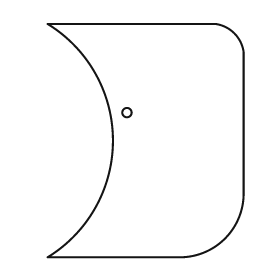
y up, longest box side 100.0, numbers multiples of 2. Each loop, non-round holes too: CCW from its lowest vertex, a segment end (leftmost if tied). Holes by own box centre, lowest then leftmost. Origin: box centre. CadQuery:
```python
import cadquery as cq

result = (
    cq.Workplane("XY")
    .moveTo(-42.0, -50.0)
    .lineTo(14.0, -50.0)
    .threePointArc((34.0, -42.0), (42.0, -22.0))
    .lineTo(42.0, 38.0)
    .threePointArc((38.0, 46.0), (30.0, 50.0))
    .lineTo(-42.0, 50.0)
    .threePointArc((-14.0, 0.0), (-42.0, -50.0))
    .close()
    .moveTo(-8.0, 12.0)
    .circle(2.0)
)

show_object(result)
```